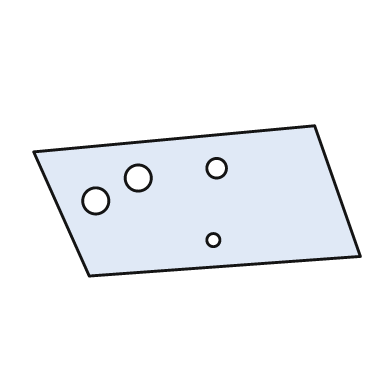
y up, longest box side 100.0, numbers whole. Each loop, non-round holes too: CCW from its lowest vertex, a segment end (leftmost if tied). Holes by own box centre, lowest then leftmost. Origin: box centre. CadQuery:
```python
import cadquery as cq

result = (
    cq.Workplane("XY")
    .moveTo(-33.0, -23.0)
    .lineTo(50.0, -17.0)
    .lineTo(36.0, 23.0)
    .lineTo(-50.0, 15.0)
    .close()
    .moveTo(5.0, -12.0)
    .circle(2.0)
    .moveTo(-31.0, 0.0)
    .circle(4.0)
    .moveTo(-18.0, 7.0)
    .circle(4.0)
    .moveTo(6.0, 10.0)
    .circle(3.0)
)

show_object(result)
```